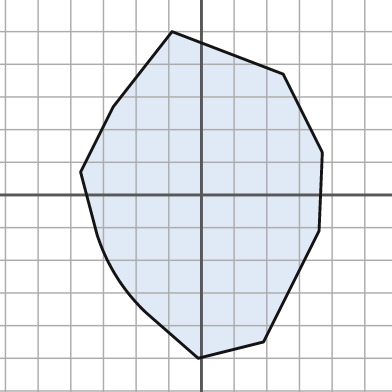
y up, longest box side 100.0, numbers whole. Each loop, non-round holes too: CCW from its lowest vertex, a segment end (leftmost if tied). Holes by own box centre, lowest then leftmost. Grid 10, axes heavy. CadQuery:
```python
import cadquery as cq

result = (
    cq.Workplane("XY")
    .moveTo(-1.0, -50.0)
    .lineTo(19.0, -45.0)
    .lineTo(36.0, -11.0)
    .lineTo(37.0, 13.0)
    .lineTo(25.0, 37.0)
    .lineTo(-9.0, 50.0)
    .lineTo(-27.0, 27.0)
    .lineTo(-37.0, 7.0)
    .lineTo(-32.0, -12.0)
    .threePointArc((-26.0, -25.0), (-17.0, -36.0))
    .close()
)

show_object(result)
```